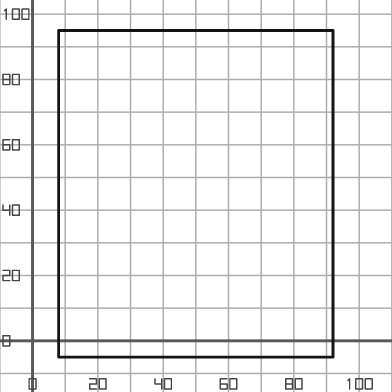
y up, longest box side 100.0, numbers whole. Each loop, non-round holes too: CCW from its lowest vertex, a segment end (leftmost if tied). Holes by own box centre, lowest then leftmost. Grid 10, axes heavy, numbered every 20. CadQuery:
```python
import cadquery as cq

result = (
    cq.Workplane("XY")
    .moveTo(8.0, -5.0)
    .lineTo(92.0, -5.0)
    .lineTo(92.0, 95.0)
    .lineTo(8.0, 95.0)
    .close()
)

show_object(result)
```